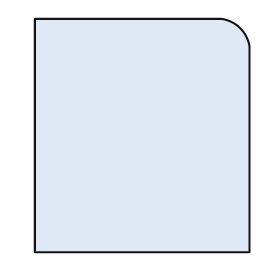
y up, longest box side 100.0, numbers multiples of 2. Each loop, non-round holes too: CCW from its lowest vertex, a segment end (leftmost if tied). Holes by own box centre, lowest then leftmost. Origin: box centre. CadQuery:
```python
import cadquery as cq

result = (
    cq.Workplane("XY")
    .moveTo(-46.0, -50.0)
    .lineTo(46.0, -50.0)
    .lineTo(46.0, 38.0)
    .threePointArc((42.0, 46.0), (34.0, 50.0))
    .lineTo(-46.0, 50.0)
    .close()
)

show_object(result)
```